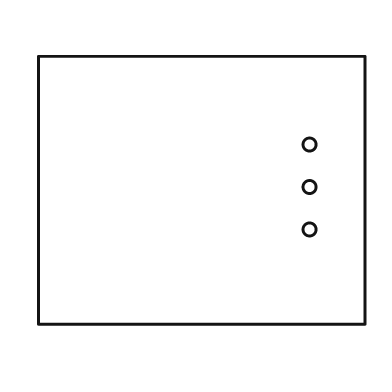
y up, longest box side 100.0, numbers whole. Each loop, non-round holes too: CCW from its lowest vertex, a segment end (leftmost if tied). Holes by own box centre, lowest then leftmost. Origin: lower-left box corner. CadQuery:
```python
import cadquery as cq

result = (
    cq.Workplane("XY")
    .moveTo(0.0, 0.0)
    .lineTo(100.0, 0.0)
    .lineTo(100.0, 82.0)
    .lineTo(0.0, 82.0)
    .close()
    .moveTo(83.0, 29.0)
    .circle(2.0)
    .moveTo(83.0, 42.0)
    .circle(2.0)
    .moveTo(83.0, 55.0)
    .circle(2.0)
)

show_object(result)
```